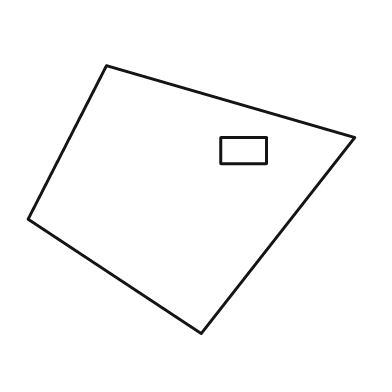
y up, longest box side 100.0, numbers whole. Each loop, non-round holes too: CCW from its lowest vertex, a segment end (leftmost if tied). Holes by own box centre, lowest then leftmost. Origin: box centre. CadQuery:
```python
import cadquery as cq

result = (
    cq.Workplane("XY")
    .moveTo(3.0, -41.0)
    .lineTo(50.0, 19.0)
    .lineTo(-26.0, 41.0)
    .lineTo(-50.0, -6.0)
    .close()
    .moveTo(9.0, 11.0)
    .lineTo(23.0, 11.0)
    .lineTo(23.0, 19.0)
    .lineTo(9.0, 19.0)
    .close()
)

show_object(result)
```